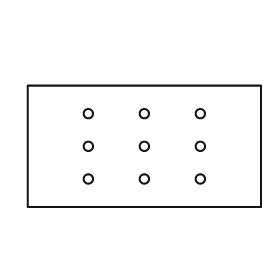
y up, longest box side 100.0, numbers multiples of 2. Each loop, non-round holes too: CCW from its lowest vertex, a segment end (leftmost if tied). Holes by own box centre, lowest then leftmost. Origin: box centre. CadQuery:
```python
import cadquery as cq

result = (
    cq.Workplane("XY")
    .moveTo(-50.0, -26.0)
    .lineTo(50.0, -26.0)
    .lineTo(50.0, 26.0)
    .lineTo(-50.0, 26.0)
    .close()
    .moveTo(-24.0, -14.0)
    .circle(2.0)
    .moveTo(0.0, -14.0)
    .circle(2.0)
    .moveTo(24.0, -14.0)
    .circle(2.0)
    .moveTo(-24.0, 0.0)
    .circle(2.0)
    .moveTo(0.0, 0.0)
    .circle(2.0)
    .moveTo(24.0, 0.0)
    .circle(2.0)
    .moveTo(-24.0, 14.0)
    .circle(2.0)
    .moveTo(0.0, 14.0)
    .circle(2.0)
    .moveTo(24.0, 14.0)
    .circle(2.0)
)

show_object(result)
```